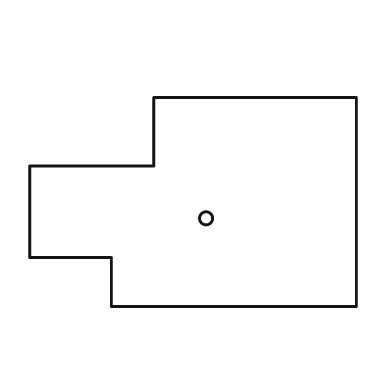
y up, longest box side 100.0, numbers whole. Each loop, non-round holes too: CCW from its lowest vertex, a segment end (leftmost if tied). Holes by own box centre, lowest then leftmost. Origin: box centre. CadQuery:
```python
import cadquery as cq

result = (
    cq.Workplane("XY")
    .moveTo(-25.0, -32.0)
    .lineTo(50.0, -32.0)
    .lineTo(50.0, 32.0)
    .lineTo(-12.0, 32.0)
    .lineTo(-12.0, 11.0)
    .lineTo(-50.0, 11.0)
    .lineTo(-50.0, -17.0)
    .lineTo(-25.0, -17.0)
    .close()
    .moveTo(4.0, -5.0)
    .circle(2.0)
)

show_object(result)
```